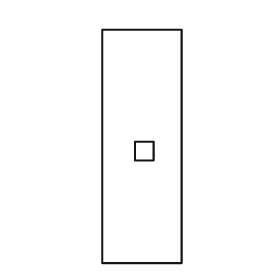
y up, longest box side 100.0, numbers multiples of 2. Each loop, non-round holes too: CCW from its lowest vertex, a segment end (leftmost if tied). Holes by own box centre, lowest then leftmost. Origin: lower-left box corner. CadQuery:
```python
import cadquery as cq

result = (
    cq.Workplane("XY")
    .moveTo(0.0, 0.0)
    .lineTo(34.0, 0.0)
    .lineTo(34.0, 100.0)
    .lineTo(0.0, 100.0)
    .close()
    .moveTo(14.0, 44.0)
    .lineTo(22.0, 44.0)
    .lineTo(22.0, 52.0)
    .lineTo(14.0, 52.0)
    .close()
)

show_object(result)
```